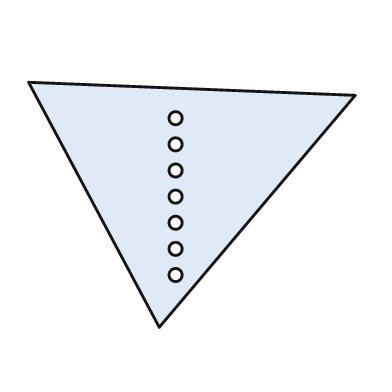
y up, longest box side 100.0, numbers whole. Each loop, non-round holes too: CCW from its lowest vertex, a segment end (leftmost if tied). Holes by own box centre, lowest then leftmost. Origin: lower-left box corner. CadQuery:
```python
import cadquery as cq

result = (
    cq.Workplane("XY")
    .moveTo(40.0, 0.0)
    .lineTo(100.0, 71.0)
    .lineTo(0.0, 75.0)
    .close()
    .moveTo(45.0, 16.0)
    .circle(2.0)
    .moveTo(45.0, 24.0)
    .circle(2.0)
    .moveTo(45.0, 32.0)
    .circle(2.0)
    .moveTo(45.0, 40.0)
    .circle(2.0)
    .moveTo(45.0, 48.0)
    .circle(2.0)
    .moveTo(45.0, 56.0)
    .circle(2.0)
    .moveTo(45.0, 64.0)
    .circle(2.0)
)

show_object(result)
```